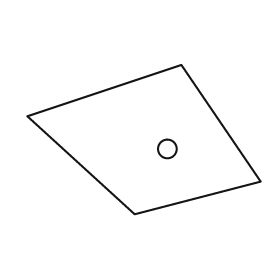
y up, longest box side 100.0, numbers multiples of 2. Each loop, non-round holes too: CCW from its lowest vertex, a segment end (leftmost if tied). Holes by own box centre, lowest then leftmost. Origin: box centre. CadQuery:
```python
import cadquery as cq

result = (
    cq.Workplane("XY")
    .moveTo(-4.0, -32.0)
    .lineTo(50.0, -18.0)
    .lineTo(16.0, 32.0)
    .lineTo(-50.0, 10.0)
    .close()
    .moveTo(10.0, -4.0)
    .circle(4.0)
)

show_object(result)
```